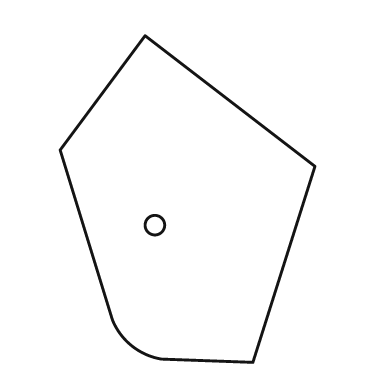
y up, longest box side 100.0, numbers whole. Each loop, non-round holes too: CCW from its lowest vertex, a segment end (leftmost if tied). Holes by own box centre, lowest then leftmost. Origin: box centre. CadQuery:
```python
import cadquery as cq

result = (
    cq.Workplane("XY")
    .moveTo(20.0, -50.0)
    .lineTo(39.0, 10.0)
    .lineTo(-13.0, 50.0)
    .lineTo(-39.0, 15.0)
    .lineTo(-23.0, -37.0)
    .threePointArc((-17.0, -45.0), (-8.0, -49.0))
    .close()
    .moveTo(-10.0, -8.0)
    .circle(3.0)
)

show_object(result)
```